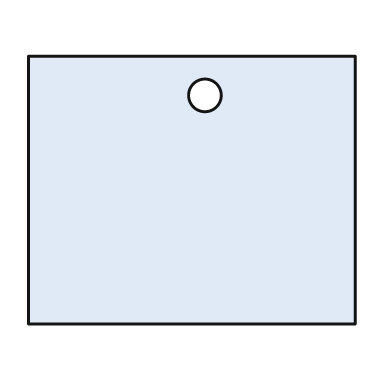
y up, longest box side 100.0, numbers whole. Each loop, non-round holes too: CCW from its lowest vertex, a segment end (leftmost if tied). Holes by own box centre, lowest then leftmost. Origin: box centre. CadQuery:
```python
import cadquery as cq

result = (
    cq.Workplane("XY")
    .moveTo(-50.0, -41.0)
    .lineTo(50.0, -41.0)
    .lineTo(50.0, 41.0)
    .lineTo(-50.0, 41.0)
    .close()
    .moveTo(4.0, 29.0)
    .circle(5.0)
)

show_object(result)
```